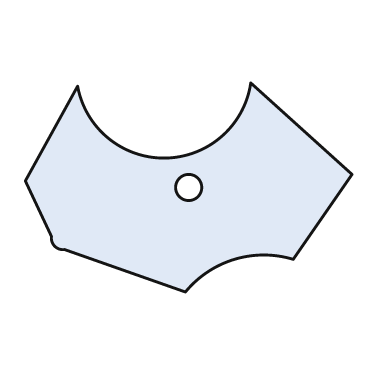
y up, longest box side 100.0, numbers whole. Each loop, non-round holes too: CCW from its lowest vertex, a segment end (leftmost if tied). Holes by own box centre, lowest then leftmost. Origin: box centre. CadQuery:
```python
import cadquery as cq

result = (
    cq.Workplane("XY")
    .moveTo(-1.0, -32.0)
    .threePointArc((14.0, -22.0), (32.0, -22.0))
    .lineTo(50.0, 4.0)
    .lineTo(19.0, 32.0)
    .threePointArc((-7.0, 9.0), (-34.0, 31.0))
    .lineTo(-50.0, 2.0)
    .lineTo(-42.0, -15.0)
    .threePointArc((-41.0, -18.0), (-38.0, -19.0))
    .close()
    .moveTo(0.0, 0.0)
    .circle(4.0)
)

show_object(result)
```